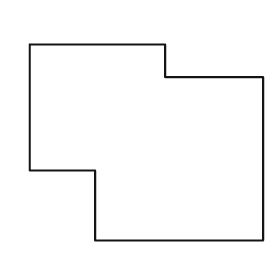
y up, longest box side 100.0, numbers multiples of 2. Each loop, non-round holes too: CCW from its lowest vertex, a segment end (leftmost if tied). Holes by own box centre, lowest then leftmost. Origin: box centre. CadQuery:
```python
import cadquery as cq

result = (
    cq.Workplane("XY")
    .moveTo(-22.0, -42.0)
    .lineTo(50.0, -42.0)
    .lineTo(50.0, 28.0)
    .lineTo(8.0, 28.0)
    .lineTo(8.0, 42.0)
    .lineTo(-50.0, 42.0)
    .lineTo(-50.0, -12.0)
    .lineTo(-22.0, -12.0)
    .close()
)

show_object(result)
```